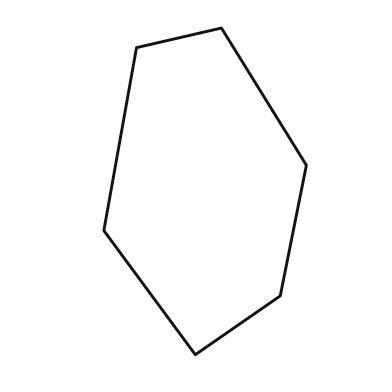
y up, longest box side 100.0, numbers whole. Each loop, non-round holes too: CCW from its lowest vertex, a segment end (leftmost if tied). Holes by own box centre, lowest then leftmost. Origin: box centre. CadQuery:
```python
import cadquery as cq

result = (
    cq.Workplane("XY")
    .moveTo(-3.0, -50.0)
    .lineTo(23.0, -32.0)
    .lineTo(31.0, 8.0)
    .lineTo(5.0, 50.0)
    .lineTo(-21.0, 44.0)
    .lineTo(-31.0, -12.0)
    .close()
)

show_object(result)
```